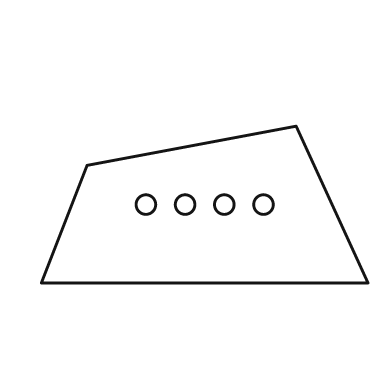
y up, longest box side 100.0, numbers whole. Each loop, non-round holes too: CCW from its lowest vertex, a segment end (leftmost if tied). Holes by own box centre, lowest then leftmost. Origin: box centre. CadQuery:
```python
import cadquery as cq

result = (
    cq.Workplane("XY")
    .moveTo(-50.0, -24.0)
    .lineTo(50.0, -24.0)
    .lineTo(28.0, 24.0)
    .lineTo(-36.0, 12.0)
    .close()
    .moveTo(-18.0, 0.0)
    .circle(3.0)
    .moveTo(-6.0, 0.0)
    .circle(3.0)
    .moveTo(6.0, 0.0)
    .circle(3.0)
    .moveTo(18.0, 0.0)
    .circle(3.0)
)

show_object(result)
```